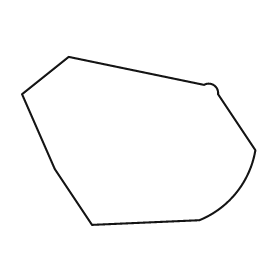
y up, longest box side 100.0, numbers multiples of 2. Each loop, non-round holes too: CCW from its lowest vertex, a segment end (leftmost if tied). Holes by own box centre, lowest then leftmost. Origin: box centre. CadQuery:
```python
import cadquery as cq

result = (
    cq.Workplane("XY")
    .moveTo(-20.0, -36.0)
    .lineTo(26.0, -34.0)
    .threePointArc((42.0, -22.0), (50.0, -4.0))
    .lineTo(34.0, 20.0)
    .threePointArc((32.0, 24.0), (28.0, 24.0))
    .lineTo(-30.0, 36.0)
    .lineTo(-50.0, 20.0)
    .lineTo(-36.0, -12.0)
    .close()
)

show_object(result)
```